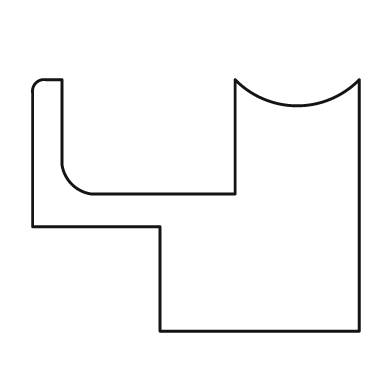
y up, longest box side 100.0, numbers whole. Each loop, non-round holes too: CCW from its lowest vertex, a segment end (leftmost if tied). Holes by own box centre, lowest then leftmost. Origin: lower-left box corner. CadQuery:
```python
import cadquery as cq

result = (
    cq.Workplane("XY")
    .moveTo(39.0, 0.0)
    .lineTo(100.0, 0.0)
    .lineTo(100.0, 77.0)
    .threePointArc((81.0, 69.0), (62.0, 77.0))
    .lineTo(62.0, 42.0)
    .lineTo(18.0, 42.0)
    .threePointArc((12.0, 45.0), (9.0, 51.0))
    .lineTo(9.0, 77.0)
    .lineTo(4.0, 77.0)
    .threePointArc((1.0, 76.0), (0.0, 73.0))
    .lineTo(0.0, 32.0)
    .lineTo(39.0, 32.0)
    .close()
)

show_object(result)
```